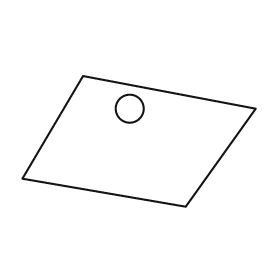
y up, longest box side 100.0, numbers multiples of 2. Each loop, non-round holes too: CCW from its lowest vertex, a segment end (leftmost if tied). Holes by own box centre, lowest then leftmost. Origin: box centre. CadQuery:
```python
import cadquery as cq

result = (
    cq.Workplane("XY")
    .moveTo(20.0, -28.0)
    .lineTo(50.0, 14.0)
    .lineTo(-24.0, 28.0)
    .lineTo(-50.0, -16.0)
    .close()
    .moveTo(-4.0, 14.0)
    .circle(6.0)
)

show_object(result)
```